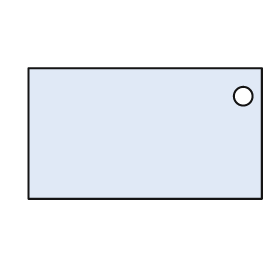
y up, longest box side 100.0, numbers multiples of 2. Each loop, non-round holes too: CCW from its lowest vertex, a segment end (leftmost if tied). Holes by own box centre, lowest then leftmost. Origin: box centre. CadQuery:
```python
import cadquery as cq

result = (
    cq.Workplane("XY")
    .moveTo(-50.0, -28.0)
    .lineTo(50.0, -28.0)
    .lineTo(50.0, 28.0)
    .lineTo(-50.0, 28.0)
    .close()
    .moveTo(42.0, 16.0)
    .circle(4.0)
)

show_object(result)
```